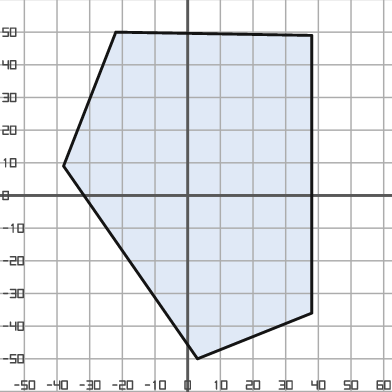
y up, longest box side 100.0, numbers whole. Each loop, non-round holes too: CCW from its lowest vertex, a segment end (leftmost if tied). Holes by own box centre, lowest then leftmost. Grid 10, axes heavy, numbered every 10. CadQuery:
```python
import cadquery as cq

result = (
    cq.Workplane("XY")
    .moveTo(3.0, -50.0)
    .lineTo(38.0, -36.0)
    .lineTo(38.0, 49.0)
    .lineTo(-22.0, 50.0)
    .lineTo(-38.0, 9.0)
    .close()
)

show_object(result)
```